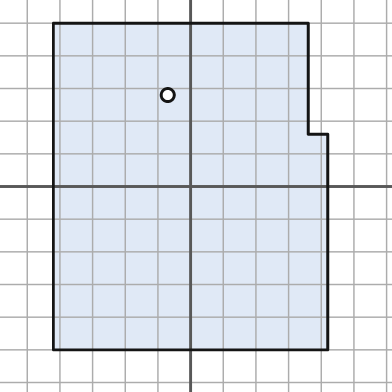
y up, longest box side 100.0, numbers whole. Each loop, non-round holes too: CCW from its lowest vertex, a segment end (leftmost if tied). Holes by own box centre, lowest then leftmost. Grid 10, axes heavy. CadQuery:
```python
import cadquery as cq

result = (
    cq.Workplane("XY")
    .moveTo(-42.0, -50.0)
    .lineTo(42.0, -50.0)
    .lineTo(42.0, 16.0)
    .lineTo(36.0, 16.0)
    .lineTo(36.0, 50.0)
    .lineTo(-42.0, 50.0)
    .close()
    .moveTo(-7.0, 28.0)
    .circle(2.0)
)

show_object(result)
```